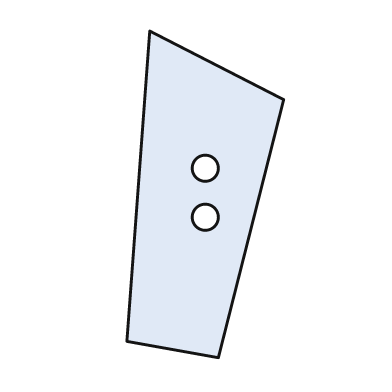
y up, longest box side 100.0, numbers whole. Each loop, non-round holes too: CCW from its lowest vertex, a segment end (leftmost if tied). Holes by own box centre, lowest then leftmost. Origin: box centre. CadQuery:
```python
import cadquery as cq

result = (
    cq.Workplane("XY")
    .moveTo(4.0, -50.0)
    .lineTo(24.0, 29.0)
    .lineTo(-17.0, 50.0)
    .lineTo(-24.0, -45.0)
    .close()
    .moveTo(0.0, -7.0)
    .circle(4.0)
    .moveTo(0.0, 8.0)
    .circle(4.0)
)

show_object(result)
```